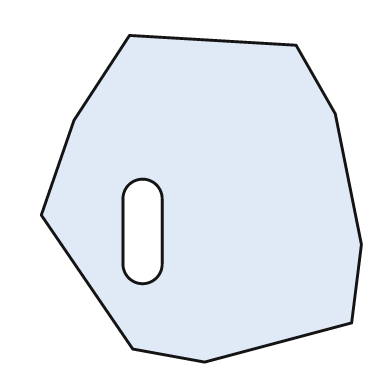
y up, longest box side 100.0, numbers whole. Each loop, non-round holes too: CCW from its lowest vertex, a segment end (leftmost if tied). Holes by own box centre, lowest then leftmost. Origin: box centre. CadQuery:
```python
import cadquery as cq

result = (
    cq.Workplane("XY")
    .moveTo(1.0, -50.0)
    .lineTo(46.0, -38.0)
    .lineTo(49.0, -14.0)
    .lineTo(41.0, 26.0)
    .lineTo(29.0, 47.0)
    .lineTo(-22.0, 50.0)
    .lineTo(-39.0, 24.0)
    .lineTo(-49.0, -5.0)
    .lineTo(-21.0, -46.0)
    .close()
    .moveTo(-24.0, -20.0)
    .threePointArc((-18.0, -26.0), (-12.0, -20.0))
    .lineTo(-12.0, 0.0)
    .threePointArc((-18.0, 6.0), (-24.0, 0.0))
    .close()
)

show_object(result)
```